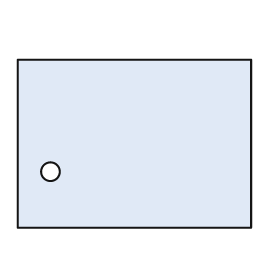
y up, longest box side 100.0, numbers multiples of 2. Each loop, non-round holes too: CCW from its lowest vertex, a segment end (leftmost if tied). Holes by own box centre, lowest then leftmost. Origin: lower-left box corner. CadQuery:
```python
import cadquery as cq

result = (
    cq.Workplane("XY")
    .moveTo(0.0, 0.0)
    .lineTo(100.0, 0.0)
    .lineTo(100.0, 72.0)
    .lineTo(0.0, 72.0)
    .close()
    .moveTo(14.0, 24.0)
    .circle(4.0)
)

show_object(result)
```